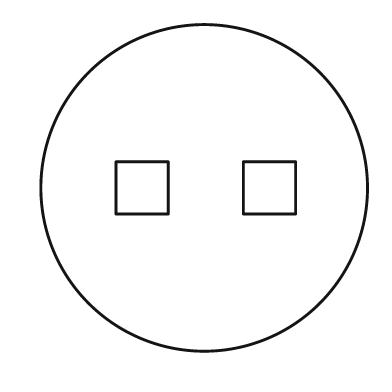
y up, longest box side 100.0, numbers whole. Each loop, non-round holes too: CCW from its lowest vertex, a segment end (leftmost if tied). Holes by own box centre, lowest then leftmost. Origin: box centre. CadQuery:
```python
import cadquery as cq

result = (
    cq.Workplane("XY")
    .moveTo(0.0, 0.0)
    .circle(50.0)
    .moveTo(-27.0, -8.0)
    .lineTo(-11.0, -8.0)
    .lineTo(-11.0, 8.0)
    .lineTo(-27.0, 8.0)
    .close()
    .moveTo(12.0, -8.0)
    .lineTo(28.0, -8.0)
    .lineTo(28.0, 8.0)
    .lineTo(12.0, 8.0)
    .close()
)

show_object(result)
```